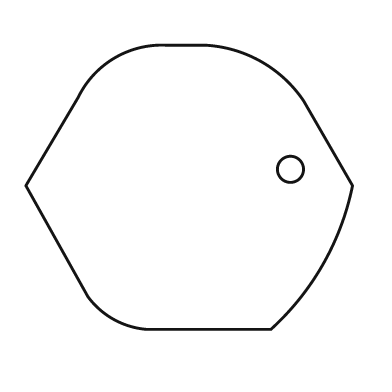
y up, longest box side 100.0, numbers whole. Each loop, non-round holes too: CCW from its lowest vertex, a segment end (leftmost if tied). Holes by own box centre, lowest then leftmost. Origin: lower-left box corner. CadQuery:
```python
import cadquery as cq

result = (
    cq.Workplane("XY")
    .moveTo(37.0, 0.0)
    .lineTo(75.0, 0.0)
    .threePointArc((91.0, 20.0), (100.0, 44.0))
    .lineTo(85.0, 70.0)
    .threePointArc((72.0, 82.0), (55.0, 87.0))
    .lineTo(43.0, 87.0)
    .threePointArc((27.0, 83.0), (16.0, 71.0))
    .lineTo(0.0, 44.0)
    .lineTo(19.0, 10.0)
    .threePointArc((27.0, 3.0), (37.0, 0.0))
    .close()
    .moveTo(81.0, 49.0)
    .circle(4.0)
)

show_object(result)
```